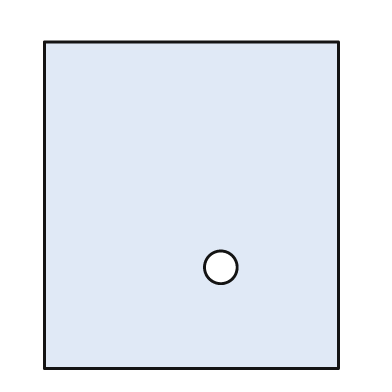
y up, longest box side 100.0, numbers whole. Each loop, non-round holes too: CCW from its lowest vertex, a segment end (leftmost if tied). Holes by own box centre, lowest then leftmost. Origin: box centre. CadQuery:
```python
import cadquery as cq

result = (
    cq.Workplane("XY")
    .moveTo(-45.0, -50.0)
    .lineTo(45.0, -50.0)
    .lineTo(45.0, 50.0)
    .lineTo(-45.0, 50.0)
    .close()
    .moveTo(9.0, -19.0)
    .circle(5.0)
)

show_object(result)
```